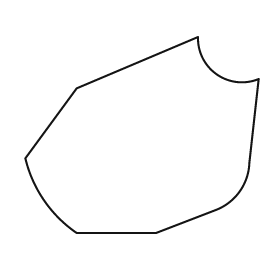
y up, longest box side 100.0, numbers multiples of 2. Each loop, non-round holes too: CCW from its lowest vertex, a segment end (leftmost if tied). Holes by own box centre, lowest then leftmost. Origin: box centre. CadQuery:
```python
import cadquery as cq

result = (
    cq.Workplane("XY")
    .moveTo(-28.0, -42.0)
    .lineTo(6.0, -42.0)
    .lineTo(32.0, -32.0)
    .threePointArc((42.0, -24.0), (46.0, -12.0))
    .lineTo(50.0, 24.0)
    .threePointArc((32.0, 26.0), (24.0, 42.0))
    .lineTo(-28.0, 20.0)
    .lineTo(-50.0, -10.0)
    .threePointArc((-42.0, -28.0), (-28.0, -42.0))
    .close()
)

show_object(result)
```